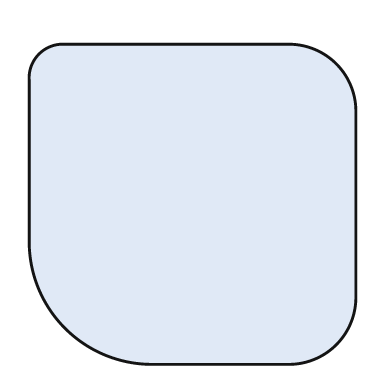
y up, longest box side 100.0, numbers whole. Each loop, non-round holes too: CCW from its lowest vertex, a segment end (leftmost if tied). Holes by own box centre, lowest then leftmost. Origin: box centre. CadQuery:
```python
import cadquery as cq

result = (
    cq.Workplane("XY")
    .moveTo(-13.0, -49.0)
    .lineTo(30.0, -49.0)
    .threePointArc((44.0, -43.0), (50.0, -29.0))
    .lineTo(50.0, 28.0)
    .threePointArc((44.0, 43.0), (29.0, 49.0))
    .lineTo(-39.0, 49.0)
    .threePointArc((-47.0, 46.0), (-50.0, 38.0))
    .lineTo(-50.0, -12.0)
    .threePointArc((-39.0, -38.0), (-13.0, -49.0))
    .close()
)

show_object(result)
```